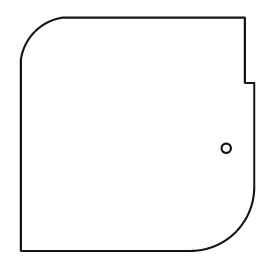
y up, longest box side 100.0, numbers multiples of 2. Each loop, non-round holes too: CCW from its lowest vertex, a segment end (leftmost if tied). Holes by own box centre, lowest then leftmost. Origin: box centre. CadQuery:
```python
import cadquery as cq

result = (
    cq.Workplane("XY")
    .moveTo(-50.0, -50.0)
    .lineTo(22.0, -50.0)
    .threePointArc((42.0, -42.0), (50.0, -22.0))
    .lineTo(50.0, 22.0)
    .lineTo(46.0, 22.0)
    .lineTo(46.0, 50.0)
    .lineTo(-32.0, 50.0)
    .threePointArc((-44.0, 44.0), (-50.0, 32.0))
    .close()
    .moveTo(38.0, -6.0)
    .circle(2.0)
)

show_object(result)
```